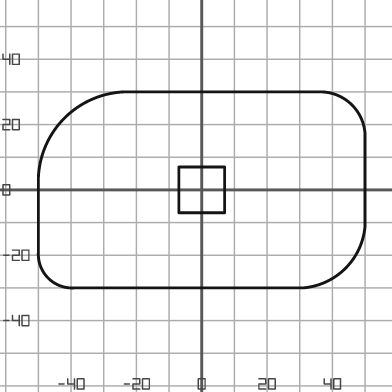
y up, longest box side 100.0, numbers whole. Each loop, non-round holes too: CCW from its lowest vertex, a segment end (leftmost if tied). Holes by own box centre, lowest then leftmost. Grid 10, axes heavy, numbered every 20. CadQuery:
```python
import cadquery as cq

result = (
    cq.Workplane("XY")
    .moveTo(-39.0, -30.0)
    .lineTo(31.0, -30.0)
    .threePointArc((44.0, -24.0), (50.0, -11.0))
    .lineTo(50.0, 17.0)
    .threePointArc((46.0, 26.0), (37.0, 30.0))
    .lineTo(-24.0, 30.0)
    .threePointArc((-42.0, 22.0), (-50.0, 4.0))
    .lineTo(-50.0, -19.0)
    .threePointArc((-47.0, -27.0), (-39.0, -30.0))
    .close()
    .moveTo(-7.0, -7.0)
    .lineTo(7.0, -7.0)
    .lineTo(7.0, 7.0)
    .lineTo(-7.0, 7.0)
    .close()
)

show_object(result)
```